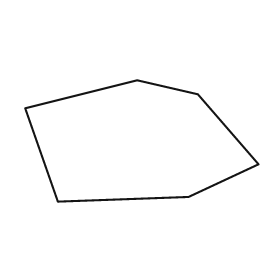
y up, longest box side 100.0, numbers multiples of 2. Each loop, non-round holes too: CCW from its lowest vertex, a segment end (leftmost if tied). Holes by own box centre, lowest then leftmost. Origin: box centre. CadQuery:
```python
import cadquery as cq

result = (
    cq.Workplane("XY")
    .moveTo(-36.0, -26.0)
    .lineTo(20.0, -24.0)
    .lineTo(50.0, -10.0)
    .lineTo(24.0, 20.0)
    .lineTo(-2.0, 26.0)
    .lineTo(-50.0, 14.0)
    .close()
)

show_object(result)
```